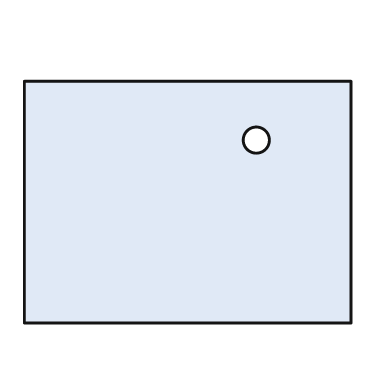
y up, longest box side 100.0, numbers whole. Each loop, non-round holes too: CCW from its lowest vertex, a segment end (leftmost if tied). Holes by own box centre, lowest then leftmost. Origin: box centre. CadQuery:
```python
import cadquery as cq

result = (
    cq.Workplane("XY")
    .moveTo(-50.0, -37.0)
    .lineTo(50.0, -37.0)
    .lineTo(50.0, 37.0)
    .lineTo(-50.0, 37.0)
    .close()
    .moveTo(21.0, 19.0)
    .circle(4.0)
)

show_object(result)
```